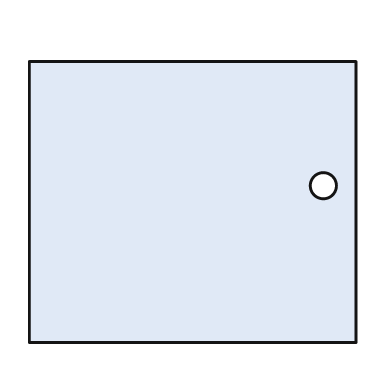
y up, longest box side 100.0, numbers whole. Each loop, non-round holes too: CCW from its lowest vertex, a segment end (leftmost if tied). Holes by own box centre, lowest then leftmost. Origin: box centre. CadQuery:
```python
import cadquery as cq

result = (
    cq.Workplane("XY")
    .moveTo(-50.0, -43.0)
    .lineTo(50.0, -43.0)
    .lineTo(50.0, 43.0)
    .lineTo(-50.0, 43.0)
    .close()
    .moveTo(40.0, 5.0)
    .circle(4.0)
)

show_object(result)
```